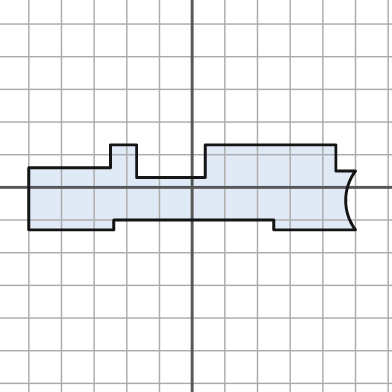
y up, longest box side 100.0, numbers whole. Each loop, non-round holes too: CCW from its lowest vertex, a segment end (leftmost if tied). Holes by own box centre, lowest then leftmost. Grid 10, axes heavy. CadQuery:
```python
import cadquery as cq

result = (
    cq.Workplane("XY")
    .moveTo(-50.0, -13.0)
    .lineTo(-24.0, -13.0)
    .lineTo(-24.0, -10.0)
    .lineTo(25.0, -10.0)
    .lineTo(25.0, -13.0)
    .lineTo(50.0, -13.0)
    .threePointArc((47.0, -4.0), (50.0, 5.0))
    .lineTo(44.0, 5.0)
    .lineTo(44.0, 13.0)
    .lineTo(4.0, 13.0)
    .lineTo(4.0, 3.0)
    .lineTo(-17.0, 3.0)
    .lineTo(-17.0, 13.0)
    .lineTo(-25.0, 13.0)
    .lineTo(-25.0, 6.0)
    .lineTo(-50.0, 6.0)
    .close()
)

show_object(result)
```